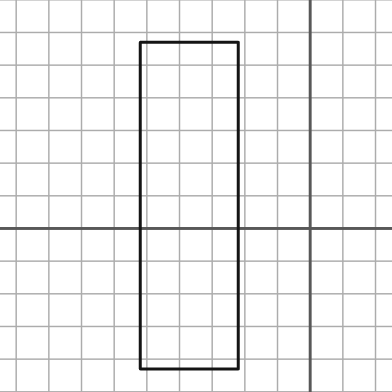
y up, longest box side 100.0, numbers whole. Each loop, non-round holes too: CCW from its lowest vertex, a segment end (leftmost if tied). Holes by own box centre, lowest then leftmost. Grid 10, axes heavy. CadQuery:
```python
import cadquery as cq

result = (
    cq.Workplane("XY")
    .moveTo(-52.0, -43.0)
    .lineTo(-22.0, -43.0)
    .lineTo(-22.0, 57.0)
    .lineTo(-52.0, 57.0)
    .close()
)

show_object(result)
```